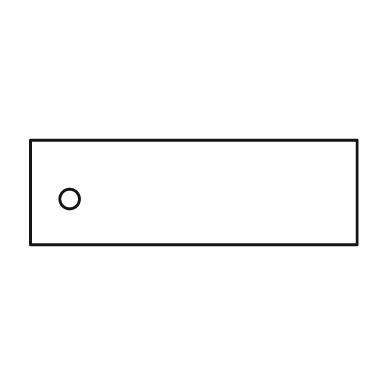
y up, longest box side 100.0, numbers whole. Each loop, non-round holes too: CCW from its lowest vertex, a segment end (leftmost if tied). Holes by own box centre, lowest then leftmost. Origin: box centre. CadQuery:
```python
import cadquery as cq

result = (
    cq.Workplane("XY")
    .moveTo(-50.0, -16.0)
    .lineTo(50.0, -16.0)
    .lineTo(50.0, 16.0)
    .lineTo(-50.0, 16.0)
    .close()
    .moveTo(-38.0, -2.0)
    .circle(3.0)
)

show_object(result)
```